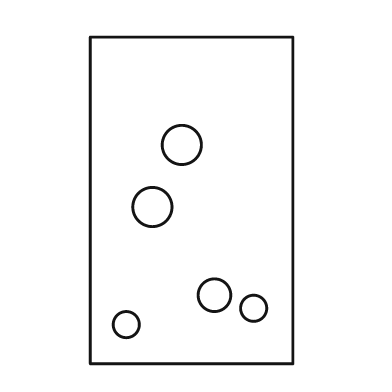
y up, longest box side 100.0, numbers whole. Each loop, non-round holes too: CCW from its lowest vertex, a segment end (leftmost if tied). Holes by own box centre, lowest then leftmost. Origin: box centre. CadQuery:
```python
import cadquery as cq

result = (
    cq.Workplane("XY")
    .moveTo(-31.0, -50.0)
    .lineTo(31.0, -50.0)
    .lineTo(31.0, 50.0)
    .lineTo(-31.0, 50.0)
    .close()
    .moveTo(-20.0, -38.0)
    .circle(4.0)
    .moveTo(19.0, -33.0)
    .circle(4.0)
    .moveTo(7.0, -29.0)
    .circle(5.0)
    .moveTo(-12.0, -2.0)
    .circle(6.0)
    .moveTo(-3.0, 17.0)
    .circle(6.0)
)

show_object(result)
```